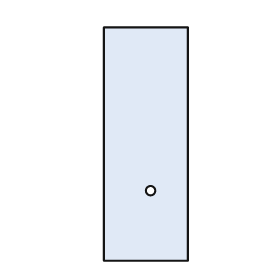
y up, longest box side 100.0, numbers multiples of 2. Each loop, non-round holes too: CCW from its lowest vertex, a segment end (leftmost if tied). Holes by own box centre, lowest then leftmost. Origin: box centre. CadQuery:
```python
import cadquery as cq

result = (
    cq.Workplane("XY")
    .moveTo(-18.0, -50.0)
    .lineTo(18.0, -50.0)
    .lineTo(18.0, 50.0)
    .lineTo(-18.0, 50.0)
    .close()
    .moveTo(2.0, -20.0)
    .circle(2.0)
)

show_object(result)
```